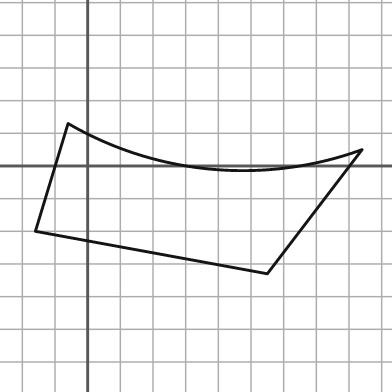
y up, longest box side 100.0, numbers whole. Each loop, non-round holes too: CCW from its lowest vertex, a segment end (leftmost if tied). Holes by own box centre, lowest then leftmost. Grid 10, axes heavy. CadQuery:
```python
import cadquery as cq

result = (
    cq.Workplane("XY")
    .moveTo(55.0, -33.0)
    .lineTo(84.0, 5.0)
    .threePointArc((38.0, -1.0), (-6.0, 13.0))
    .lineTo(-16.0, -20.0)
    .close()
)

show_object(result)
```